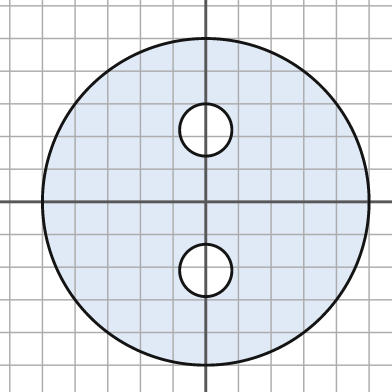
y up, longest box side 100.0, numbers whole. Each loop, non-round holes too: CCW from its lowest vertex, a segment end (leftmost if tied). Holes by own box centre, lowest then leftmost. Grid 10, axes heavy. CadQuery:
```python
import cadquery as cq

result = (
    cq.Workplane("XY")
    .moveTo(0.0, 0.0)
    .circle(50.0)
    .moveTo(0.0, -21.0)
    .circle(8.0)
    .moveTo(0.0, 22.0)
    .circle(8.0)
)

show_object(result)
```